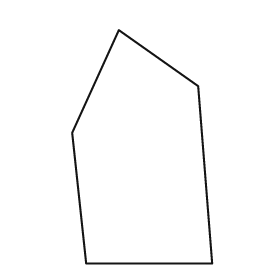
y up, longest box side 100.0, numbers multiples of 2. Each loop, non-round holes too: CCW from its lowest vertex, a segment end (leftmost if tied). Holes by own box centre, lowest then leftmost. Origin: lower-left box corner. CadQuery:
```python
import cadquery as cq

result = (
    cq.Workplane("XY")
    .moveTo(6.0, 0.0)
    .lineTo(60.0, 0.0)
    .lineTo(54.0, 76.0)
    .lineTo(20.0, 100.0)
    .lineTo(0.0, 56.0)
    .close()
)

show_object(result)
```